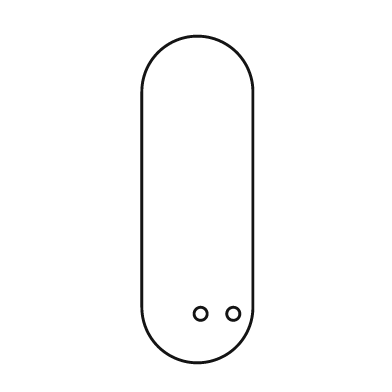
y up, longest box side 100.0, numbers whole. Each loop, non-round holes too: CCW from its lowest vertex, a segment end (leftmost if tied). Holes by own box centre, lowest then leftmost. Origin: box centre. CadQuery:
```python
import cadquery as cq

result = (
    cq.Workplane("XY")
    .moveTo(-17.0, -33.0)
    .threePointArc((0.0, -50.0), (17.0, -33.0))
    .lineTo(17.0, 33.0)
    .threePointArc((0.0, 50.0), (-17.0, 33.0))
    .close()
    .moveTo(1.0, -35.0)
    .circle(2.0)
    .moveTo(11.0, -35.0)
    .circle(2.0)
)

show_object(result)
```